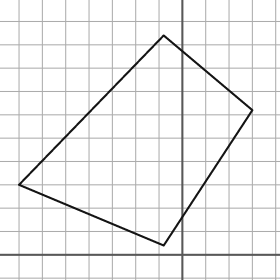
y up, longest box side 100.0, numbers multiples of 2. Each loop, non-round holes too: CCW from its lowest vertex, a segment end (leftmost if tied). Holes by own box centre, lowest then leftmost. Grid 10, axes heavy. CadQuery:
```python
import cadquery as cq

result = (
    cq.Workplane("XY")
    .moveTo(-8.0, 4.0)
    .lineTo(30.0, 62.0)
    .lineTo(-8.0, 94.0)
    .lineTo(-70.0, 30.0)
    .close()
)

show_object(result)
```